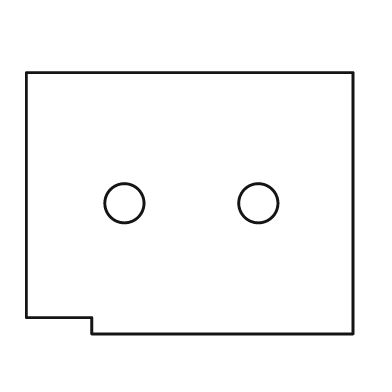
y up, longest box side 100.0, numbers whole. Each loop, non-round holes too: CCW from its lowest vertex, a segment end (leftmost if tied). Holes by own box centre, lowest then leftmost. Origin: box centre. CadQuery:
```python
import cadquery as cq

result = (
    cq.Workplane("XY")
    .moveTo(-30.0, -40.0)
    .lineTo(50.0, -40.0)
    .lineTo(50.0, 40.0)
    .lineTo(-50.0, 40.0)
    .lineTo(-50.0, -35.0)
    .lineTo(-30.0, -35.0)
    .close()
    .moveTo(-20.0, 0.0)
    .circle(6.0)
    .moveTo(21.0, 0.0)
    .circle(6.0)
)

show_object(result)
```